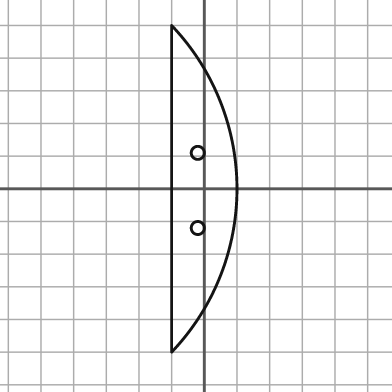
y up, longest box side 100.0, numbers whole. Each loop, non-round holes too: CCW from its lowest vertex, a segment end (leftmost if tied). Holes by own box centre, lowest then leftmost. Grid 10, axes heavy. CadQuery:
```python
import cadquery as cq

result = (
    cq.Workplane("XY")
    .moveTo(-10.0, -50.0)
    .threePointArc((10.0, 0.0), (-10.0, 50.0))
    .close()
    .moveTo(-2.0, -12.0)
    .circle(2.0)
    .moveTo(-2.0, 11.0)
    .circle(2.0)
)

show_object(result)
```